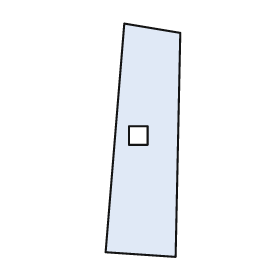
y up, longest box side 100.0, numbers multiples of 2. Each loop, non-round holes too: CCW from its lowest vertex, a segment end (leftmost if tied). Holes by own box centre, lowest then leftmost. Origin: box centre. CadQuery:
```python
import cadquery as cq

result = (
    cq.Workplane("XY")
    .moveTo(14.0, -50.0)
    .lineTo(16.0, 46.0)
    .lineTo(-8.0, 50.0)
    .lineTo(-16.0, -48.0)
    .close()
    .moveTo(-6.0, -2.0)
    .lineTo(2.0, -2.0)
    .lineTo(2.0, 6.0)
    .lineTo(-6.0, 6.0)
    .close()
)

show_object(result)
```